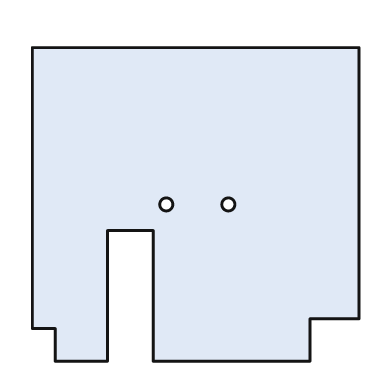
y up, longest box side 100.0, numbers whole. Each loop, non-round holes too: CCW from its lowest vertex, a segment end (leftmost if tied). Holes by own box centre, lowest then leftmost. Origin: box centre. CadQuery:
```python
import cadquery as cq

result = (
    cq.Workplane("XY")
    .moveTo(-43.0, -48.0)
    .lineTo(-27.0, -48.0)
    .lineTo(-27.0, -8.0)
    .lineTo(-13.0, -8.0)
    .lineTo(-13.0, -48.0)
    .lineTo(35.0, -48.0)
    .lineTo(35.0, -35.0)
    .lineTo(50.0, -35.0)
    .lineTo(50.0, 48.0)
    .lineTo(-50.0, 48.0)
    .lineTo(-50.0, -38.0)
    .lineTo(-43.0, -38.0)
    .close()
    .moveTo(-9.0, 0.0)
    .circle(2.0)
    .moveTo(10.0, 0.0)
    .circle(2.0)
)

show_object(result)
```